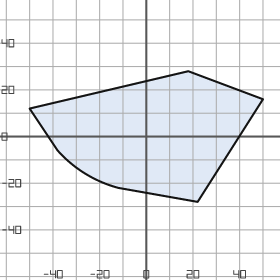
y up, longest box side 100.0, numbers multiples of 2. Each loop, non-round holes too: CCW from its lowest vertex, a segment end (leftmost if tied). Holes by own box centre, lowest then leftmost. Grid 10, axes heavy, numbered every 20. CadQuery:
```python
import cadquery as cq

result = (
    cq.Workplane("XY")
    .moveTo(22.0, -28.0)
    .lineTo(50.0, 16.0)
    .lineTo(18.0, 28.0)
    .lineTo(-50.0, 12.0)
    .lineTo(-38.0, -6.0)
    .threePointArc((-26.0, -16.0), (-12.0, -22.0))
    .close()
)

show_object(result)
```